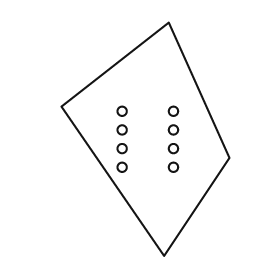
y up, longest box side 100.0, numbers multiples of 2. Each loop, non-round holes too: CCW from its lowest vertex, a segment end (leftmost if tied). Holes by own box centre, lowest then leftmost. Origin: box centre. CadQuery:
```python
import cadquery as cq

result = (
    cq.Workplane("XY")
    .moveTo(8.0, -50.0)
    .lineTo(36.0, -8.0)
    .lineTo(10.0, 50.0)
    .lineTo(-36.0, 14.0)
    .close()
    .moveTo(-10.0, -12.0)
    .circle(2.0)
    .moveTo(12.0, -12.0)
    .circle(2.0)
    .moveTo(-10.0, -4.0)
    .circle(2.0)
    .moveTo(12.0, -4.0)
    .circle(2.0)
    .moveTo(-10.0, 4.0)
    .circle(2.0)
    .moveTo(12.0, 4.0)
    .circle(2.0)
    .moveTo(-10.0, 12.0)
    .circle(2.0)
    .moveTo(12.0, 12.0)
    .circle(2.0)
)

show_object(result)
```